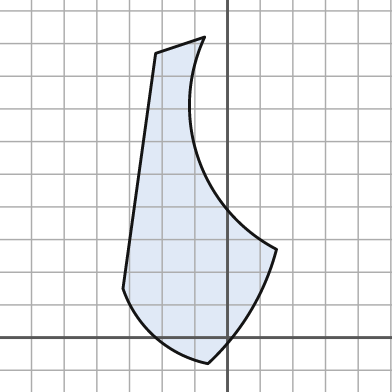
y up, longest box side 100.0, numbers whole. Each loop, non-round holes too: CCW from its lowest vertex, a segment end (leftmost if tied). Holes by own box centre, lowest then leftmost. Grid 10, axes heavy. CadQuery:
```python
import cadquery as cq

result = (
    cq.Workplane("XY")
    .moveTo(-6.0, -8.0)
    .threePointArc((7.0, 8.0), (15.0, 27.0))
    .threePointArc((-9.0, 55.0), (-7.0, 92.0))
    .lineTo(-22.0, 87.0)
    .lineTo(-32.0, 15.0)
    .threePointArc((-22.0, 0.0), (-6.0, -8.0))
    .close()
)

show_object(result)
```